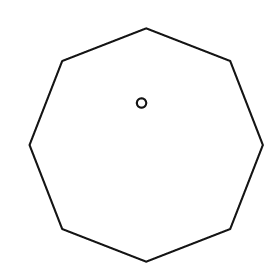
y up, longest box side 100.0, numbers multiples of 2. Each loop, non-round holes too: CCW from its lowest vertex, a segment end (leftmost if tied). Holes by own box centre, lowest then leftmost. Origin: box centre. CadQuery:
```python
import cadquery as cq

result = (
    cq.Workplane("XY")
    .moveTo(0.0, -50.0)
    .lineTo(36.0, -36.0)
    .lineTo(50.0, 0.0)
    .lineTo(36.0, 36.0)
    .lineTo(0.0, 50.0)
    .lineTo(-36.0, 36.0)
    .lineTo(-50.0, 0.0)
    .lineTo(-36.0, -36.0)
    .close()
    .moveTo(-2.0, 18.0)
    .circle(2.0)
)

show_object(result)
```